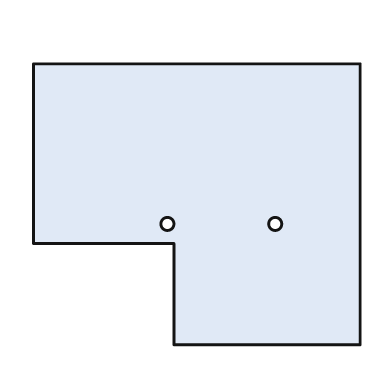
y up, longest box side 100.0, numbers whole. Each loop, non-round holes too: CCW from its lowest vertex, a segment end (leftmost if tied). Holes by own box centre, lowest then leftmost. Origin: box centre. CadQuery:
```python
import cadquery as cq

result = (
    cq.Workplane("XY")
    .moveTo(-7.0, -43.0)
    .lineTo(50.0, -43.0)
    .lineTo(50.0, 43.0)
    .lineTo(-50.0, 43.0)
    .lineTo(-50.0, -12.0)
    .lineTo(-7.0, -12.0)
    .close()
    .moveTo(-9.0, -6.0)
    .circle(2.0)
    .moveTo(24.0, -6.0)
    .circle(2.0)
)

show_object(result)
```